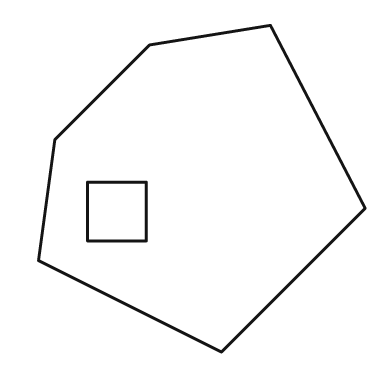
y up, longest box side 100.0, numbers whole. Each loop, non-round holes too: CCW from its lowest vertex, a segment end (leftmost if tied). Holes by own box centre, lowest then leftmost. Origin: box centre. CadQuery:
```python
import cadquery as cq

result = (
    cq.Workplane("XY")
    .moveTo(6.0, -50.0)
    .lineTo(50.0, -6.0)
    .lineTo(21.0, 50.0)
    .lineTo(-16.0, 44.0)
    .lineTo(-45.0, 15.0)
    .lineTo(-50.0, -22.0)
    .close()
    .moveTo(-35.0, -16.0)
    .lineTo(-17.0, -16.0)
    .lineTo(-17.0, 2.0)
    .lineTo(-35.0, 2.0)
    .close()
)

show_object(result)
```